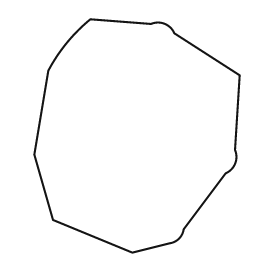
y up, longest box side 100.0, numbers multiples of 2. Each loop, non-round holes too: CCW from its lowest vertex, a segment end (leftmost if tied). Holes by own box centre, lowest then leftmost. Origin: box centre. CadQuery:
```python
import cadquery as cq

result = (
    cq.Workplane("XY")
    .moveTo(-2.0, -50.0)
    .lineTo(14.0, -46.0)
    .threePointArc((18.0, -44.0), (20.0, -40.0))
    .lineTo(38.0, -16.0)
    .threePointArc((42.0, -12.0), (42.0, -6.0))
    .lineTo(44.0, 26.0)
    .lineTo(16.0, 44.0)
    .threePointArc((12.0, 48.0), (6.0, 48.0))
    .lineTo(-20.0, 50.0)
    .threePointArc((-30.0, 40.0), (-38.0, 28.0))
    .lineTo(-44.0, -8.0)
    .lineTo(-36.0, -36.0)
    .close()
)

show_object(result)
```